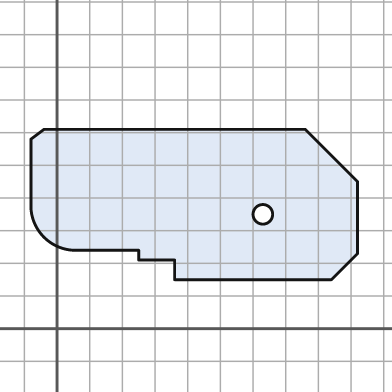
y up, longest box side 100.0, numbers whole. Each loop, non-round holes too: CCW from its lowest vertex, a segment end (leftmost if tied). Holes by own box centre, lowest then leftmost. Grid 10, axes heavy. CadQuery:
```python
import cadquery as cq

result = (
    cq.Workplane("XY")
    .moveTo(36.0, 15.0)
    .lineTo(84.0, 15.0)
    .lineTo(92.0, 23.0)
    .lineTo(92.0, 45.0)
    .lineTo(76.0, 61.0)
    .lineTo(-4.0, 61.0)
    .lineTo(-8.0, 58.0)
    .lineTo(-8.0, 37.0)
    .threePointArc((-4.0, 28.0), (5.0, 24.0))
    .lineTo(25.0, 24.0)
    .lineTo(25.0, 21.0)
    .lineTo(36.0, 21.0)
    .close()
    .moveTo(63.0, 35.0)
    .circle(3.0)
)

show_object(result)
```